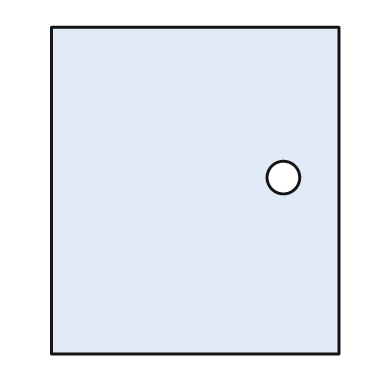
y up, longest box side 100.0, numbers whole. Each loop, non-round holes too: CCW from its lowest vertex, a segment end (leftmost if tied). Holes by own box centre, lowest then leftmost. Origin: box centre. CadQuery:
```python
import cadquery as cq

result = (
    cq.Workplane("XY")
    .moveTo(-44.0, -50.0)
    .lineTo(44.0, -50.0)
    .lineTo(44.0, 50.0)
    .lineTo(-44.0, 50.0)
    .close()
    .moveTo(27.0, 4.0)
    .circle(5.0)
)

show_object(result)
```